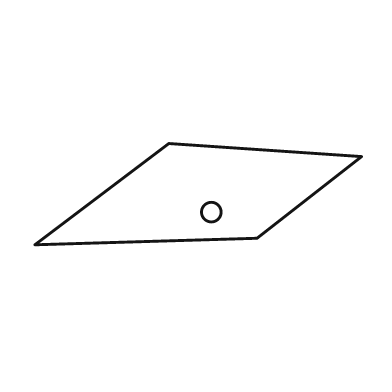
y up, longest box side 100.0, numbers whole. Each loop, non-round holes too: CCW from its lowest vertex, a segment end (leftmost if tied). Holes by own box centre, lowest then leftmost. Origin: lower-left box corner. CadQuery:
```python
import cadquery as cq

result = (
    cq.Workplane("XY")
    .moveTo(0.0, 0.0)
    .lineTo(68.0, 2.0)
    .lineTo(100.0, 27.0)
    .lineTo(41.0, 31.0)
    .close()
    .moveTo(54.0, 10.0)
    .circle(3.0)
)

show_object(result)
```